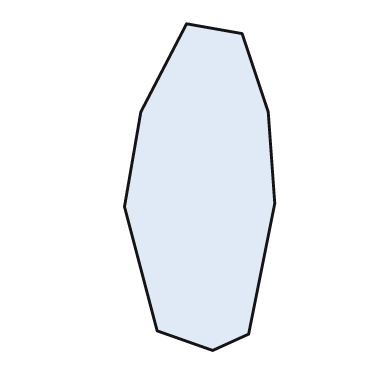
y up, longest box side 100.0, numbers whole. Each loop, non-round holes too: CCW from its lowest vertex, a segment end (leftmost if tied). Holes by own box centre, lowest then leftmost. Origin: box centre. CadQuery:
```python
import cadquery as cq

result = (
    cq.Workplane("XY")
    .moveTo(4.0, -50.0)
    .lineTo(15.0, -45.0)
    .lineTo(23.0, -5.0)
    .lineTo(21.0, 23.0)
    .lineTo(13.0, 47.0)
    .lineTo(-4.0, 50.0)
    .lineTo(-18.0, 23.0)
    .lineTo(-23.0, -6.0)
    .lineTo(-13.0, -44.0)
    .close()
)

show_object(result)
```